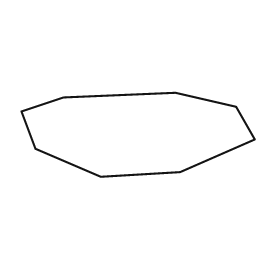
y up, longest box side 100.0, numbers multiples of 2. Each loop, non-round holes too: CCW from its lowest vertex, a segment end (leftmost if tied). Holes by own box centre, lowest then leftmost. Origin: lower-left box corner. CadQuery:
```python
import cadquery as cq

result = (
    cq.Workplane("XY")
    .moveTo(34.0, 0.0)
    .lineTo(68.0, 2.0)
    .lineTo(100.0, 16.0)
    .lineTo(92.0, 30.0)
    .lineTo(66.0, 36.0)
    .lineTo(18.0, 34.0)
    .lineTo(0.0, 28.0)
    .lineTo(6.0, 12.0)
    .close()
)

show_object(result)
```